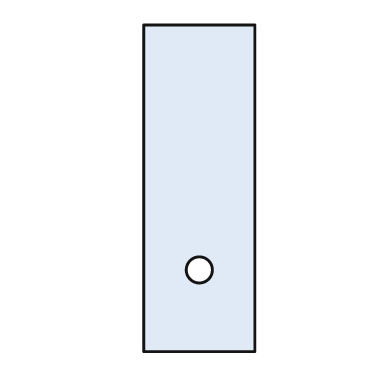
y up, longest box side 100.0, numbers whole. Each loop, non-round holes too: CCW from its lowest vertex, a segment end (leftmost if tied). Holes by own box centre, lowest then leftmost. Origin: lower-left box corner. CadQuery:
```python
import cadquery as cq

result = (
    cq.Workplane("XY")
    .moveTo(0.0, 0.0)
    .lineTo(34.0, 0.0)
    .lineTo(34.0, 100.0)
    .lineTo(0.0, 100.0)
    .close()
    .moveTo(17.0, 25.0)
    .circle(4.0)
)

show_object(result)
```